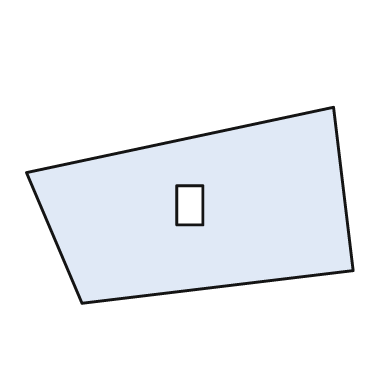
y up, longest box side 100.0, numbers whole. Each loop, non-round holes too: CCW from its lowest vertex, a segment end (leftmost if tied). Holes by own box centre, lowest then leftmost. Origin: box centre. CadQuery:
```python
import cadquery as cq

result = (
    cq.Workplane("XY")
    .moveTo(-33.0, -30.0)
    .lineTo(50.0, -20.0)
    .lineTo(44.0, 30.0)
    .lineTo(-50.0, 10.0)
    .close()
    .moveTo(-4.0, -6.0)
    .lineTo(4.0, -6.0)
    .lineTo(4.0, 6.0)
    .lineTo(-4.0, 6.0)
    .close()
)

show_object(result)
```